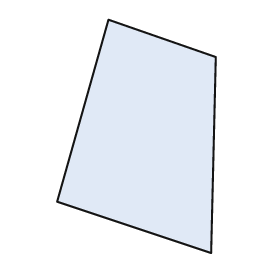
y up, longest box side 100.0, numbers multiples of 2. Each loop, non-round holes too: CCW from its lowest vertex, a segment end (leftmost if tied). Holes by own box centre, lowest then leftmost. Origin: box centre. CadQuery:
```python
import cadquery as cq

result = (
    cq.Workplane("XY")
    .moveTo(32.0, -50.0)
    .lineTo(34.0, 34.0)
    .lineTo(-12.0, 50.0)
    .lineTo(-34.0, -28.0)
    .close()
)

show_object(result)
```